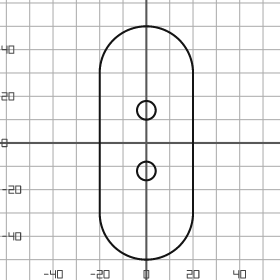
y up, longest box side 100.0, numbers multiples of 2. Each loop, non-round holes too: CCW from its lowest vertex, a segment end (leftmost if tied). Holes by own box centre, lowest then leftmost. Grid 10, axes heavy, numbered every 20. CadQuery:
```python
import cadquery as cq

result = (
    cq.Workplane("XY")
    .moveTo(-20.0, -30.0)
    .threePointArc((0.0, -50.0), (20.0, -30.0))
    .lineTo(20.0, 30.0)
    .threePointArc((0.0, 50.0), (-20.0, 30.0))
    .close()
    .moveTo(0.0, -12.0)
    .circle(4.0)
    .moveTo(0.0, 14.0)
    .circle(4.0)
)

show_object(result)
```